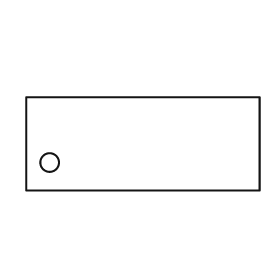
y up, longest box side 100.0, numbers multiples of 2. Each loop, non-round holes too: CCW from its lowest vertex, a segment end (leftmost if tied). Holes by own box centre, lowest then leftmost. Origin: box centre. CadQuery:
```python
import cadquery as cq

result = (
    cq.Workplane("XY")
    .moveTo(-50.0, -20.0)
    .lineTo(50.0, -20.0)
    .lineTo(50.0, 20.0)
    .lineTo(-50.0, 20.0)
    .close()
    .moveTo(-40.0, -8.0)
    .circle(4.0)
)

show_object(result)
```